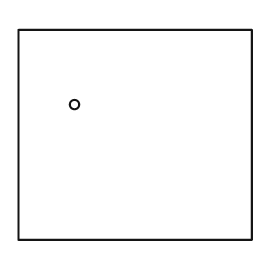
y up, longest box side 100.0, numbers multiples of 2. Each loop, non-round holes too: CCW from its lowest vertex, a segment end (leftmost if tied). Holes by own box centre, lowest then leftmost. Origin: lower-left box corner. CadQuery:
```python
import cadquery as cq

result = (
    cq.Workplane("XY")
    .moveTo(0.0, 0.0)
    .lineTo(100.0, 0.0)
    .lineTo(100.0, 90.0)
    .lineTo(0.0, 90.0)
    .close()
    .moveTo(24.0, 58.0)
    .circle(2.0)
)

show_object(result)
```